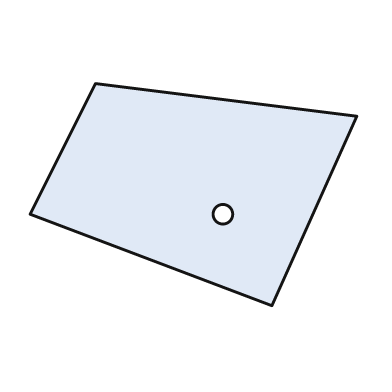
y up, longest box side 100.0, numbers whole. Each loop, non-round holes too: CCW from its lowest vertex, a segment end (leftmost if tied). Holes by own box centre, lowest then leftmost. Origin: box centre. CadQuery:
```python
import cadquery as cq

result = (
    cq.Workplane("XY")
    .moveTo(24.0, -34.0)
    .lineTo(50.0, 24.0)
    .lineTo(-30.0, 34.0)
    .lineTo(-50.0, -6.0)
    .close()
    .moveTo(9.0, -6.0)
    .circle(3.0)
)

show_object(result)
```